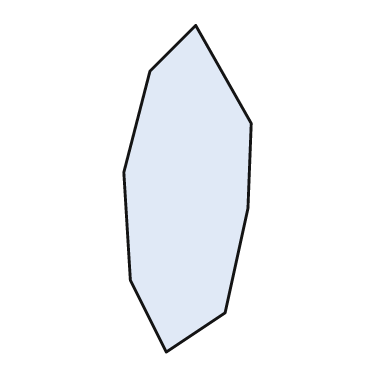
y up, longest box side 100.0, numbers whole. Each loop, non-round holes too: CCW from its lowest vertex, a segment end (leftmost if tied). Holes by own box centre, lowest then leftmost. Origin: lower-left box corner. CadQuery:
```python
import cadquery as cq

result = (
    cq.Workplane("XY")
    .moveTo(13.0, 0.0)
    .lineTo(31.0, 12.0)
    .lineTo(38.0, 44.0)
    .lineTo(39.0, 70.0)
    .lineTo(22.0, 100.0)
    .lineTo(8.0, 86.0)
    .lineTo(0.0, 55.0)
    .lineTo(2.0, 22.0)
    .close()
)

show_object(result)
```